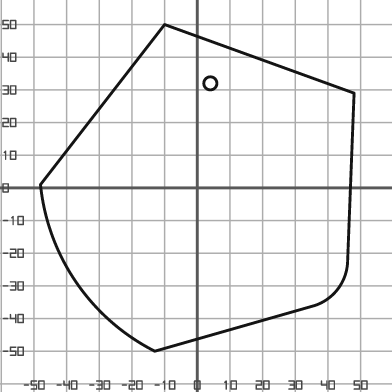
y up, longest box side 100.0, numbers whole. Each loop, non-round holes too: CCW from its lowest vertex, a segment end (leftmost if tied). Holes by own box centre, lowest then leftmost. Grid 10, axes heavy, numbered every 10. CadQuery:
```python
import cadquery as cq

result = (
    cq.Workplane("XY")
    .moveTo(-13.0, -50.0)
    .lineTo(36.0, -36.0)
    .threePointArc((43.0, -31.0), (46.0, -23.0))
    .lineTo(48.0, 29.0)
    .lineTo(-10.0, 50.0)
    .lineTo(-48.0, 1.0)
    .threePointArc((-37.0, -29.0), (-13.0, -50.0))
    .close()
    .moveTo(4.0, 32.0)
    .circle(2.0)
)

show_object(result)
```